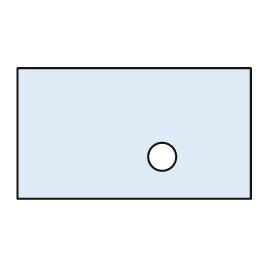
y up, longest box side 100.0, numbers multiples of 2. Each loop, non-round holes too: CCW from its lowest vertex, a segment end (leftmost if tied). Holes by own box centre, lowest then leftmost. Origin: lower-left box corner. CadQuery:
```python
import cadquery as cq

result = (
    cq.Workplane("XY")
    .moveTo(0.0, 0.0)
    .lineTo(100.0, 0.0)
    .lineTo(100.0, 56.0)
    .lineTo(0.0, 56.0)
    .close()
    .moveTo(62.0, 18.0)
    .circle(6.0)
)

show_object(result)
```